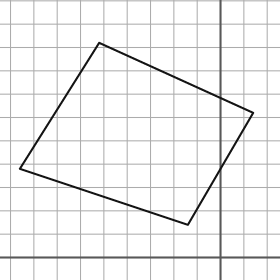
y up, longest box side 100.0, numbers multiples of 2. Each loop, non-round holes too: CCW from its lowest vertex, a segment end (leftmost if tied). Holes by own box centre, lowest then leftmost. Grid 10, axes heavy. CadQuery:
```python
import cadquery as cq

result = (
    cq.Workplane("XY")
    .moveTo(-14.0, 14.0)
    .lineTo(14.0, 62.0)
    .lineTo(-52.0, 92.0)
    .lineTo(-86.0, 38.0)
    .close()
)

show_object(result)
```